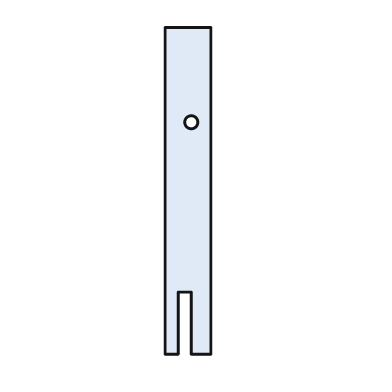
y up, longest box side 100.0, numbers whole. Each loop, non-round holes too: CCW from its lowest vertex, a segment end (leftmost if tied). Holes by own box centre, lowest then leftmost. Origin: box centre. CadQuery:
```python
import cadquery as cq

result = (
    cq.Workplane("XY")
    .moveTo(-7.0, -50.0)
    .lineTo(-3.0, -50.0)
    .lineTo(-3.0, -31.0)
    .lineTo(1.0, -31.0)
    .lineTo(1.0, -50.0)
    .lineTo(7.0, -50.0)
    .lineTo(7.0, 50.0)
    .lineTo(-7.0, 50.0)
    .close()
    .moveTo(1.0, 21.0)
    .circle(2.0)
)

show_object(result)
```